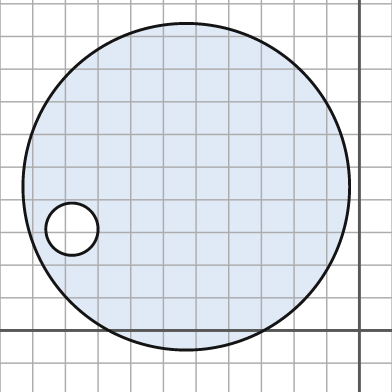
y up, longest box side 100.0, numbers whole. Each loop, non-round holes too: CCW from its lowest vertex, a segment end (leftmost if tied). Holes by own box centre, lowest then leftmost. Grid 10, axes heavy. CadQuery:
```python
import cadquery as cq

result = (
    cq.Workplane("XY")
    .moveTo(-53.0, 44.0)
    .circle(50.0)
    .moveTo(-88.0, 31.0)
    .circle(8.0)
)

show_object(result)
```